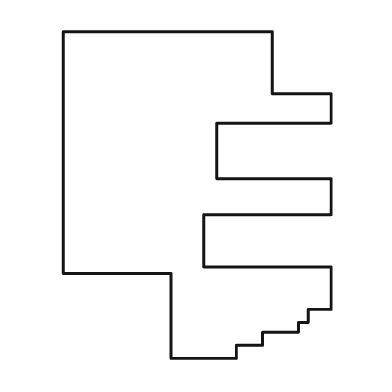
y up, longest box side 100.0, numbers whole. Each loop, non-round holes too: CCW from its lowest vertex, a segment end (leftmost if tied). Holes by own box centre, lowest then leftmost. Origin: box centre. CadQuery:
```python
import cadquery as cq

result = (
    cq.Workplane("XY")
    .moveTo(-8.0, -50.0)
    .lineTo(12.0, -50.0)
    .lineTo(12.0, -46.0)
    .lineTo(20.0, -46.0)
    .lineTo(20.0, -42.0)
    .lineTo(31.0, -42.0)
    .lineTo(31.0, -39.0)
    .lineTo(34.0, -39.0)
    .lineTo(34.0, -35.0)
    .lineTo(41.0, -35.0)
    .lineTo(41.0, -22.0)
    .lineTo(2.0, -22.0)
    .lineTo(2.0, -6.0)
    .lineTo(41.0, -6.0)
    .lineTo(41.0, 5.0)
    .lineTo(6.0, 5.0)
    .lineTo(6.0, 22.0)
    .lineTo(41.0, 22.0)
    .lineTo(41.0, 31.0)
    .lineTo(23.0, 31.0)
    .lineTo(23.0, 50.0)
    .lineTo(-41.0, 50.0)
    .lineTo(-41.0, -24.0)
    .lineTo(-8.0, -24.0)
    .close()
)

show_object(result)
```